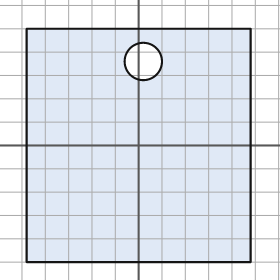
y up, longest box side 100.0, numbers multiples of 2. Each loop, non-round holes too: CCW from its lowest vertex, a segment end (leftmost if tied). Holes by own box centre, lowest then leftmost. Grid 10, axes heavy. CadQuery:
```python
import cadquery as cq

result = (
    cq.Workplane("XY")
    .moveTo(-48.0, -50.0)
    .lineTo(48.0, -50.0)
    .lineTo(48.0, 50.0)
    .lineTo(-48.0, 50.0)
    .close()
    .moveTo(2.0, 36.0)
    .circle(8.0)
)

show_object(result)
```